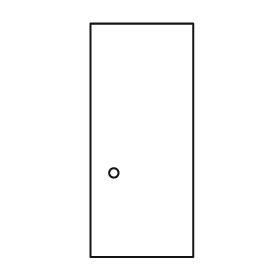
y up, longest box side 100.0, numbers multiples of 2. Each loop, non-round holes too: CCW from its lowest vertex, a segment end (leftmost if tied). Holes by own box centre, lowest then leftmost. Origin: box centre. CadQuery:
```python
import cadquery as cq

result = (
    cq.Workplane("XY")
    .moveTo(-22.0, -50.0)
    .lineTo(22.0, -50.0)
    .lineTo(22.0, 50.0)
    .lineTo(-22.0, 50.0)
    .close()
    .moveTo(-12.0, -14.0)
    .circle(2.0)
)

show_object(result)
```